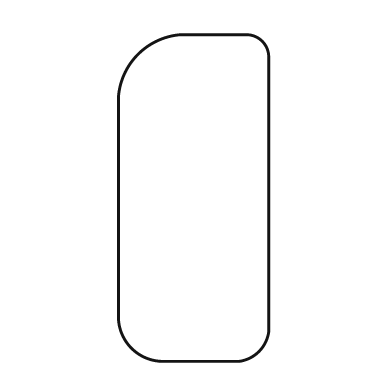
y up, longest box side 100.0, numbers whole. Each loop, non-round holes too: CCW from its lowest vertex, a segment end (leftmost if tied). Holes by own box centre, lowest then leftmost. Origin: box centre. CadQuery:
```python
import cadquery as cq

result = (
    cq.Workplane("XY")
    .moveTo(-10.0, -50.0)
    .lineTo(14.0, -50.0)
    .threePointArc((20.0, -47.0), (23.0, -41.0))
    .lineTo(23.0, 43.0)
    .threePointArc((21.0, 48.0), (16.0, 50.0))
    .lineTo(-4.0, 50.0)
    .threePointArc((-17.0, 44.0), (-23.0, 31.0))
    .lineTo(-23.0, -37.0)
    .threePointArc((-19.0, -46.0), (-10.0, -50.0))
    .close()
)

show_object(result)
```